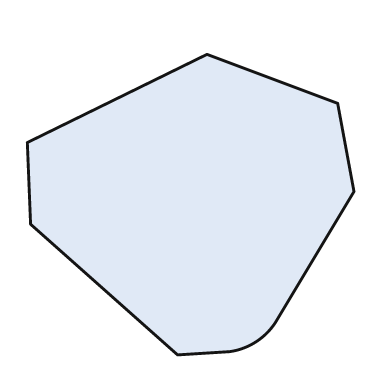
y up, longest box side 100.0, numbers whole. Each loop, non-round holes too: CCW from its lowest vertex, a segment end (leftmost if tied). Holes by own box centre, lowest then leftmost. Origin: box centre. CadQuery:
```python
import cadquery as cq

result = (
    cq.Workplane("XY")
    .moveTo(-4.0, -46.0)
    .lineTo(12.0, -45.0)
    .threePointArc((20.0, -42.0), (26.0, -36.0))
    .lineTo(50.0, 4.0)
    .lineTo(45.0, 31.0)
    .lineTo(5.0, 46.0)
    .lineTo(-50.0, 19.0)
    .lineTo(-49.0, -6.0)
    .close()
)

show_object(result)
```